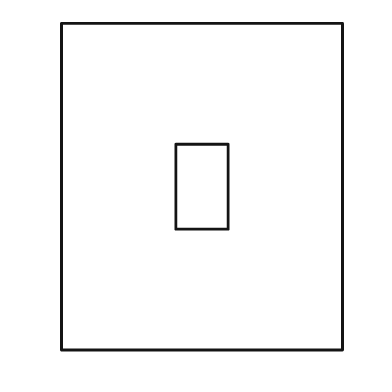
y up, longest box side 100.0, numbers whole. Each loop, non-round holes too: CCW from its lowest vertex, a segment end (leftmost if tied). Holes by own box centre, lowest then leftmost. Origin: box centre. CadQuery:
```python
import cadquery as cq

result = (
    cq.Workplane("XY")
    .moveTo(-43.0, -50.0)
    .lineTo(43.0, -50.0)
    .lineTo(43.0, 50.0)
    .lineTo(-43.0, 50.0)
    .close()
    .moveTo(-8.0, -13.0)
    .lineTo(8.0, -13.0)
    .lineTo(8.0, 13.0)
    .lineTo(-8.0, 13.0)
    .close()
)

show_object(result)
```